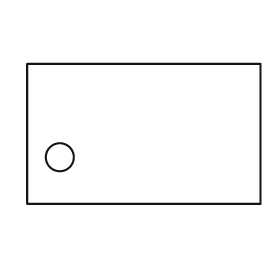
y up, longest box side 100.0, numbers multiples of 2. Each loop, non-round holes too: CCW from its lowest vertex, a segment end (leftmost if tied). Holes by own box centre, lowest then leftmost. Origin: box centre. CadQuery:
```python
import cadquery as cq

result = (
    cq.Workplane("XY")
    .moveTo(-50.0, -30.0)
    .lineTo(50.0, -30.0)
    .lineTo(50.0, 30.0)
    .lineTo(-50.0, 30.0)
    .close()
    .moveTo(-36.0, -10.0)
    .circle(6.0)
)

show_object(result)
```